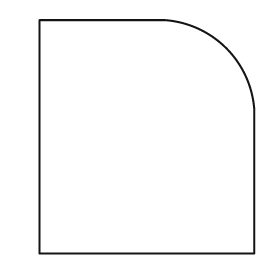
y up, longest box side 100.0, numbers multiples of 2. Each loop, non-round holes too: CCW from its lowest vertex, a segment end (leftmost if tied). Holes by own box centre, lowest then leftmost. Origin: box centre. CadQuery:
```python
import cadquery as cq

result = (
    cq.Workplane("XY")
    .moveTo(-46.0, -50.0)
    .lineTo(46.0, -50.0)
    .lineTo(46.0, 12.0)
    .threePointArc((34.0, 38.0), (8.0, 50.0))
    .lineTo(-46.0, 50.0)
    .close()
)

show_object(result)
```